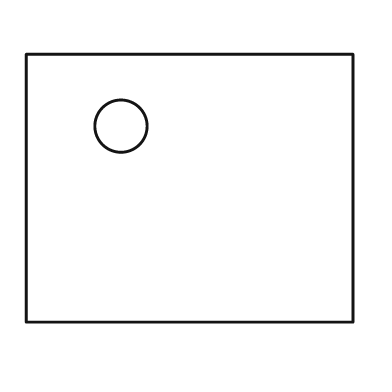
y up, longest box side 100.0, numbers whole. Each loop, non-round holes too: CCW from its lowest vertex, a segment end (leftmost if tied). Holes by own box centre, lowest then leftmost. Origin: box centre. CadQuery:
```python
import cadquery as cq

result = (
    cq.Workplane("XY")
    .moveTo(-50.0, -41.0)
    .lineTo(50.0, -41.0)
    .lineTo(50.0, 41.0)
    .lineTo(-50.0, 41.0)
    .close()
    .moveTo(-21.0, 19.0)
    .circle(8.0)
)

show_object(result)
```